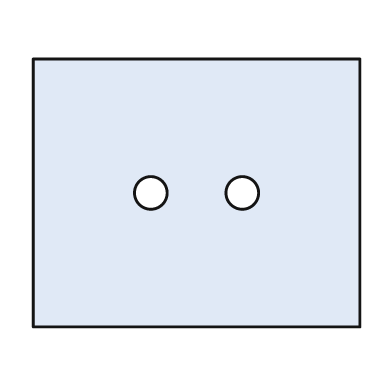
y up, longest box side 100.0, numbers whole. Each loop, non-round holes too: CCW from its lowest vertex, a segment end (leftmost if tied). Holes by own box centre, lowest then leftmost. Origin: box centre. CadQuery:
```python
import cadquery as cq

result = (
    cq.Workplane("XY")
    .moveTo(-50.0, -41.0)
    .lineTo(50.0, -41.0)
    .lineTo(50.0, 41.0)
    .lineTo(-50.0, 41.0)
    .close()
    .moveTo(-14.0, 0.0)
    .circle(5.0)
    .moveTo(14.0, 0.0)
    .circle(5.0)
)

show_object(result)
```